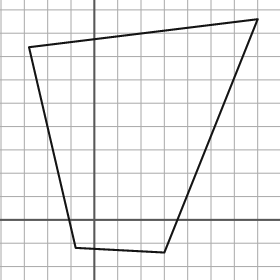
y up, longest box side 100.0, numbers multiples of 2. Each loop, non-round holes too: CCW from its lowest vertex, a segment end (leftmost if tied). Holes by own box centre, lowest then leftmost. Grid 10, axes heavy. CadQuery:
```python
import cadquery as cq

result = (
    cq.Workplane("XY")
    .moveTo(30.0, -14.0)
    .lineTo(70.0, 86.0)
    .lineTo(-28.0, 74.0)
    .lineTo(-8.0, -12.0)
    .close()
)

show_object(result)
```